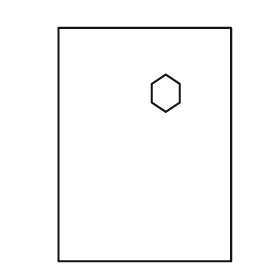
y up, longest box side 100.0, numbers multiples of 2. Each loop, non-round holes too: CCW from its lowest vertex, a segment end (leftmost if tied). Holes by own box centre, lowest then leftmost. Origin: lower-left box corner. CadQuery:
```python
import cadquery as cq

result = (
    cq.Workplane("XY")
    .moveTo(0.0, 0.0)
    .lineTo(74.0, 0.0)
    .lineTo(74.0, 100.0)
    .lineTo(0.0, 100.0)
    .close()
    .moveTo(46.0, 64.0)
    .lineTo(52.0, 68.0)
    .lineTo(52.0, 76.0)
    .lineTo(46.0, 80.0)
    .lineTo(40.0, 76.0)
    .lineTo(40.0, 68.0)
    .close()
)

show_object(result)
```